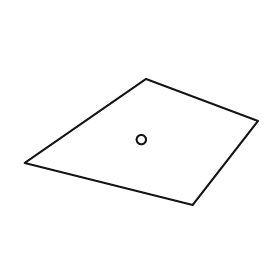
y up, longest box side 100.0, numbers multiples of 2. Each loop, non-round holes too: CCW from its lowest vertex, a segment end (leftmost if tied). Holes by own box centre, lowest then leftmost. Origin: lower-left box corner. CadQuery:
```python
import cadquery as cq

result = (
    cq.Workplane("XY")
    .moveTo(72.0, 0.0)
    .lineTo(100.0, 36.0)
    .lineTo(52.0, 54.0)
    .lineTo(0.0, 18.0)
    .close()
    .moveTo(50.0, 28.0)
    .circle(2.0)
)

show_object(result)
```